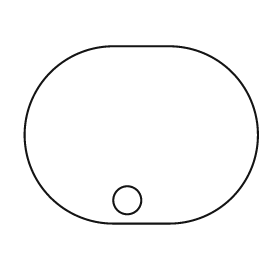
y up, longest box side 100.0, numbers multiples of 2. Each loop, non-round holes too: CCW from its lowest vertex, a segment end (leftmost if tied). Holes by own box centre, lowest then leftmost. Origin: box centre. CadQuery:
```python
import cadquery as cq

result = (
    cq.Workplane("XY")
    .moveTo(-12.0, -38.0)
    .lineTo(12.0, -38.0)
    .threePointArc((50.0, 0.0), (12.0, 38.0))
    .lineTo(-12.0, 38.0)
    .threePointArc((-50.0, 0.0), (-12.0, -38.0))
    .close()
    .moveTo(-6.0, -28.0)
    .circle(6.0)
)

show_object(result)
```